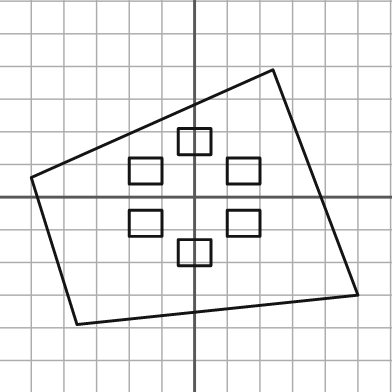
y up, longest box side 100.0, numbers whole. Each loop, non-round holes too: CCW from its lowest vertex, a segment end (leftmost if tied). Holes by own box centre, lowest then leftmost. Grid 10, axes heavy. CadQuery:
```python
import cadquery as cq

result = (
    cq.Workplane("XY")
    .moveTo(-36.0, -39.0)
    .lineTo(50.0, -30.0)
    .lineTo(24.0, 39.0)
    .lineTo(-50.0, 6.0)
    .close()
    .moveTo(-5.0, -21.0)
    .lineTo(5.0, -21.0)
    .lineTo(5.0, -13.0)
    .lineTo(-5.0, -13.0)
    .close()
    .moveTo(-20.0, -12.0)
    .lineTo(-10.0, -12.0)
    .lineTo(-10.0, -4.0)
    .lineTo(-20.0, -4.0)
    .close()
    .moveTo(10.0, -12.0)
    .lineTo(20.0, -12.0)
    .lineTo(20.0, -4.0)
    .lineTo(10.0, -4.0)
    .close()
    .moveTo(-20.0, 4.0)
    .lineTo(-10.0, 4.0)
    .lineTo(-10.0, 12.0)
    .lineTo(-20.0, 12.0)
    .close()
    .moveTo(10.0, 4.0)
    .lineTo(20.0, 4.0)
    .lineTo(20.0, 12.0)
    .lineTo(10.0, 12.0)
    .close()
    .moveTo(-5.0, 13.0)
    .lineTo(5.0, 13.0)
    .lineTo(5.0, 21.0)
    .lineTo(-5.0, 21.0)
    .close()
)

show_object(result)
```